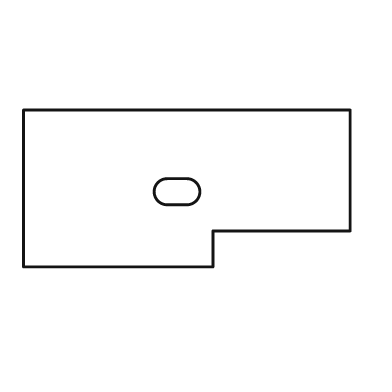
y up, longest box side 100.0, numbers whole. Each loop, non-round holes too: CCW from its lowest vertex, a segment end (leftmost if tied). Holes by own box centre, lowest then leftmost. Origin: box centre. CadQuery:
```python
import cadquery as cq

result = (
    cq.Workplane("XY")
    .moveTo(-50.0, -24.0)
    .lineTo(8.0, -24.0)
    .lineTo(8.0, -13.0)
    .lineTo(50.0, -13.0)
    .lineTo(50.0, 24.0)
    .lineTo(-50.0, 24.0)
    .close()
    .moveTo(-6.0, -5.0)
    .lineTo(0.0, -5.0)
    .threePointArc((4.0, -1.0), (0.0, 3.0))
    .lineTo(-6.0, 3.0)
    .threePointArc((-10.0, -1.0), (-6.0, -5.0))
    .close()
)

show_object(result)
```